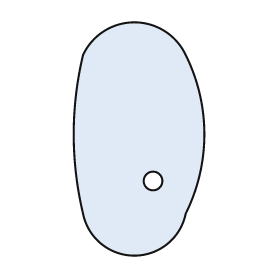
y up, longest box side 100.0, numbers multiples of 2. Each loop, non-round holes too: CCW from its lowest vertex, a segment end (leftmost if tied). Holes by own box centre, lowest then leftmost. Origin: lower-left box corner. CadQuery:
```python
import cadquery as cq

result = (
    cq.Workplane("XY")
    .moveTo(4.0, 18.0)
    .threePointArc((26.0, 0.0), (48.0, 18.0))
    .threePointArc((56.0, 52.0), (48.0, 86.0))
    .threePointArc((26.0, 100.0), (4.0, 86.0))
    .threePointArc((0.0, 52.0), (4.0, 18.0))
    .close()
    .moveTo(34.0, 32.0)
    .circle(4.0)
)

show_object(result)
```